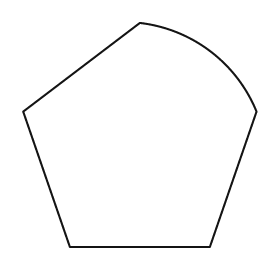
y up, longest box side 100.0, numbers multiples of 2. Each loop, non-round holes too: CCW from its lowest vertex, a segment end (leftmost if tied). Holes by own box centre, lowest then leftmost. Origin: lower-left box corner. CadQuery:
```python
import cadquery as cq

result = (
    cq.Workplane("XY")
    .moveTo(20.0, 0.0)
    .lineTo(80.0, 0.0)
    .lineTo(100.0, 58.0)
    .threePointArc((80.0, 84.0), (50.0, 96.0))
    .lineTo(0.0, 58.0)
    .close()
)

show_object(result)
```